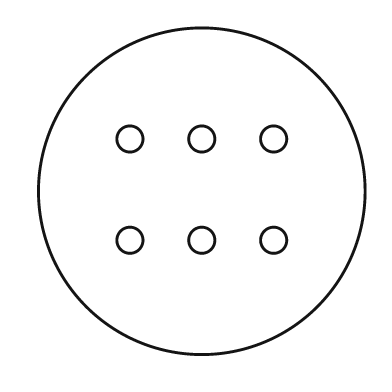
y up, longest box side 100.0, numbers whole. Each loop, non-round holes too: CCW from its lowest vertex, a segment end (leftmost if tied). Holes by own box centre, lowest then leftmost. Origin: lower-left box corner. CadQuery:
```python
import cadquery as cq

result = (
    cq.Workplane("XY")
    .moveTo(50.0, 50.0)
    .circle(50.0)
    .moveTo(28.0, 35.0)
    .circle(4.0)
    .moveTo(50.0, 35.0)
    .circle(4.0)
    .moveTo(72.0, 35.0)
    .circle(4.0)
    .moveTo(28.0, 66.0)
    .circle(4.0)
    .moveTo(50.0, 66.0)
    .circle(4.0)
    .moveTo(72.0, 66.0)
    .circle(4.0)
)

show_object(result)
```